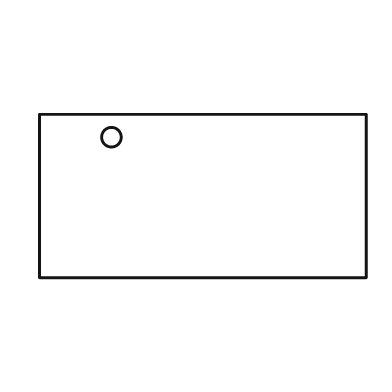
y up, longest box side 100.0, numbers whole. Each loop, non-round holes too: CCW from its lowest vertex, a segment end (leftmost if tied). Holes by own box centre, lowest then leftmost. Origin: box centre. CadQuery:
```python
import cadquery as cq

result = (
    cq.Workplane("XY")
    .moveTo(-50.0, -25.0)
    .lineTo(50.0, -25.0)
    .lineTo(50.0, 25.0)
    .lineTo(-50.0, 25.0)
    .close()
    .moveTo(-28.0, 18.0)
    .circle(3.0)
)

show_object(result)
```